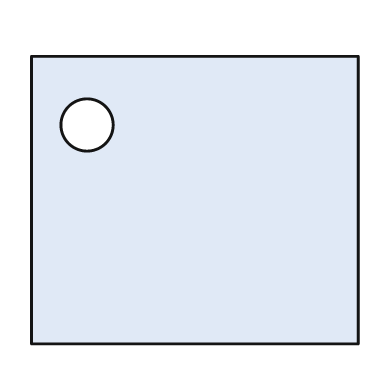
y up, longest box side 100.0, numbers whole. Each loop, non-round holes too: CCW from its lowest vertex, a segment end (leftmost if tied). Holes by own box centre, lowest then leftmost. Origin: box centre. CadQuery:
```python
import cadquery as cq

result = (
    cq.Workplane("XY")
    .moveTo(-50.0, -44.0)
    .lineTo(50.0, -44.0)
    .lineTo(50.0, 44.0)
    .lineTo(-50.0, 44.0)
    .close()
    .moveTo(-33.0, 23.0)
    .circle(8.0)
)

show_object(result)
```